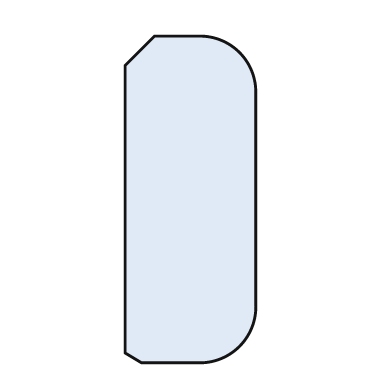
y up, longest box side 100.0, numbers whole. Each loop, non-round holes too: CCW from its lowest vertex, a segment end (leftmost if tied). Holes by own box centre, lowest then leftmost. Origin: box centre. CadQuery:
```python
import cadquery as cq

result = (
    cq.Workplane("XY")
    .moveTo(-15.0, -50.0)
    .lineTo(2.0, -50.0)
    .threePointArc((15.0, -45.0), (20.0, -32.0))
    .lineTo(20.0, 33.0)
    .threePointArc((15.0, 45.0), (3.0, 50.0))
    .lineTo(-11.0, 50.0)
    .lineTo(-20.0, 41.0)
    .lineTo(-20.0, -47.0)
    .close()
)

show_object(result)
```